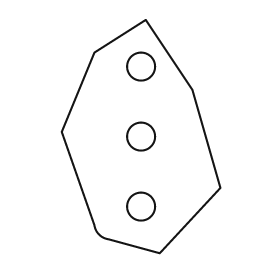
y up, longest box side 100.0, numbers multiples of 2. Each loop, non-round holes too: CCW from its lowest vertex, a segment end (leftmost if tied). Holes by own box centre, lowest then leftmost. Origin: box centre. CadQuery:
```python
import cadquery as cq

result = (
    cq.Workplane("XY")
    .moveTo(8.0, -50.0)
    .lineTo(34.0, -22.0)
    .lineTo(22.0, 20.0)
    .lineTo(2.0, 50.0)
    .lineTo(-20.0, 36.0)
    .lineTo(-34.0, 2.0)
    .lineTo(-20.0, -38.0)
    .threePointArc((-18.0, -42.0), (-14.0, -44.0))
    .close()
    .moveTo(0.0, -30.0)
    .circle(6.0)
    .moveTo(0.0, 0.0)
    .circle(6.0)
    .moveTo(0.0, 30.0)
    .circle(6.0)
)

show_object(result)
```